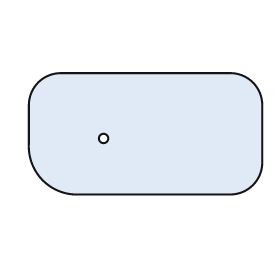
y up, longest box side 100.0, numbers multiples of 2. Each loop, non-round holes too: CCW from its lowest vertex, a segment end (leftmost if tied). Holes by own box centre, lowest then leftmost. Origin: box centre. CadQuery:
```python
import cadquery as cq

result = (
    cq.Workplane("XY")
    .moveTo(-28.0, -26.0)
    .lineTo(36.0, -26.0)
    .threePointArc((46.0, -22.0), (50.0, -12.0))
    .lineTo(50.0, 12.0)
    .threePointArc((46.0, 22.0), (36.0, 26.0))
    .lineTo(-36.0, 26.0)
    .threePointArc((-46.0, 22.0), (-50.0, 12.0))
    .lineTo(-50.0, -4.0)
    .threePointArc((-44.0, -20.0), (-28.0, -26.0))
    .close()
    .moveTo(-18.0, -2.0)
    .circle(2.0)
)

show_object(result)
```